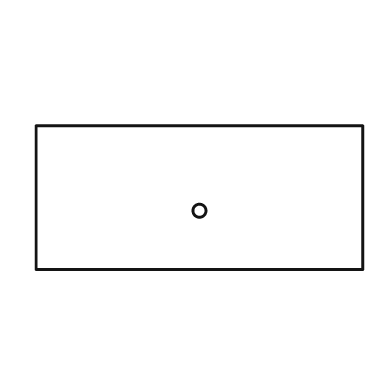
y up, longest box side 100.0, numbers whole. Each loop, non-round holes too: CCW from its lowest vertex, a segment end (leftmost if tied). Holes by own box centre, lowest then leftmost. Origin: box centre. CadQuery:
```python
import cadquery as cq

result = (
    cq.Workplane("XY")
    .moveTo(-50.0, -22.0)
    .lineTo(50.0, -22.0)
    .lineTo(50.0, 22.0)
    .lineTo(-50.0, 22.0)
    .close()
    .moveTo(0.0, -4.0)
    .circle(2.0)
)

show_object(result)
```